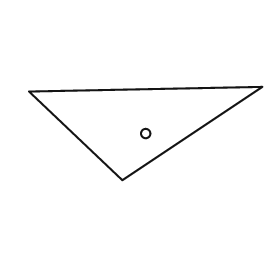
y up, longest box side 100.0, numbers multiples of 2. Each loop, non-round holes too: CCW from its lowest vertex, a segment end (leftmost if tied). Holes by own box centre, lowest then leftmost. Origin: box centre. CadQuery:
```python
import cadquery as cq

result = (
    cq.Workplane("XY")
    .moveTo(-10.0, -20.0)
    .lineTo(50.0, 20.0)
    .lineTo(-50.0, 18.0)
    .close()
    .moveTo(0.0, 0.0)
    .circle(2.0)
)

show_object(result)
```